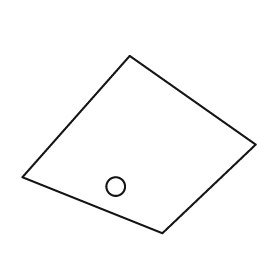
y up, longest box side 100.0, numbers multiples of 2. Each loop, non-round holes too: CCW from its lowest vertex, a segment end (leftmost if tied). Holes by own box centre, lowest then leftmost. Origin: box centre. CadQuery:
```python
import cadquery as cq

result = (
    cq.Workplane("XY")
    .moveTo(10.0, -38.0)
    .lineTo(50.0, 0.0)
    .lineTo(-4.0, 38.0)
    .lineTo(-50.0, -14.0)
    .close()
    .moveTo(-10.0, -18.0)
    .circle(4.0)
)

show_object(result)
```